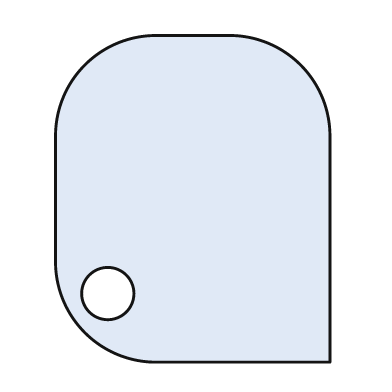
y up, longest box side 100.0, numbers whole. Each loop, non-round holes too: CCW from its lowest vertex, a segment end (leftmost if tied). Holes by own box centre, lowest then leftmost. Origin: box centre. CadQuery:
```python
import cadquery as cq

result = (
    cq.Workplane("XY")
    .moveTo(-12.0, -50.0)
    .lineTo(42.0, -50.0)
    .lineTo(42.0, 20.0)
    .threePointArc((33.0, 41.0), (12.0, 50.0))
    .lineTo(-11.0, 50.0)
    .threePointArc((-33.0, 41.0), (-42.0, 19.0))
    .lineTo(-42.0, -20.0)
    .threePointArc((-33.0, -41.0), (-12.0, -50.0))
    .close()
    .moveTo(-26.0, -29.0)
    .circle(8.0)
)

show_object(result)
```